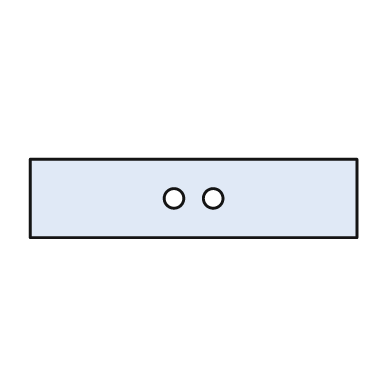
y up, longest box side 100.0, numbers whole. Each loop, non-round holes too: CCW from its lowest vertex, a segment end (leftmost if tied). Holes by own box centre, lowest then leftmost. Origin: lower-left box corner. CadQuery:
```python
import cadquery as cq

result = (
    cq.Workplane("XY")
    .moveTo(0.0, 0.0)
    .lineTo(100.0, 0.0)
    .lineTo(100.0, 24.0)
    .lineTo(0.0, 24.0)
    .close()
    .moveTo(44.0, 12.0)
    .circle(3.0)
    .moveTo(56.0, 12.0)
    .circle(3.0)
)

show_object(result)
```